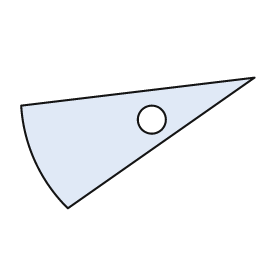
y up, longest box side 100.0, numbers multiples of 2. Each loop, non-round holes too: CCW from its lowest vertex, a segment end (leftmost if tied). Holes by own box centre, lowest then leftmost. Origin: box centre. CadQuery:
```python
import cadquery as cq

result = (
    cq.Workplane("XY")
    .moveTo(-30.0, -28.0)
    .lineTo(50.0, 28.0)
    .lineTo(-50.0, 16.0)
    .threePointArc((-44.0, -8.0), (-30.0, -28.0))
    .close()
    .moveTo(6.0, 10.0)
    .circle(6.0)
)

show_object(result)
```